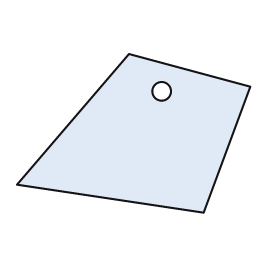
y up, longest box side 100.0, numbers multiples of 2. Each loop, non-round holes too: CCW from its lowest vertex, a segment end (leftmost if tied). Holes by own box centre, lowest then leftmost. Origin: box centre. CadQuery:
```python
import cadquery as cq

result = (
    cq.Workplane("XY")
    .moveTo(30.0, -34.0)
    .lineTo(50.0, 20.0)
    .lineTo(-2.0, 34.0)
    .lineTo(-50.0, -22.0)
    .close()
    .moveTo(12.0, 18.0)
    .circle(4.0)
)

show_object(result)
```